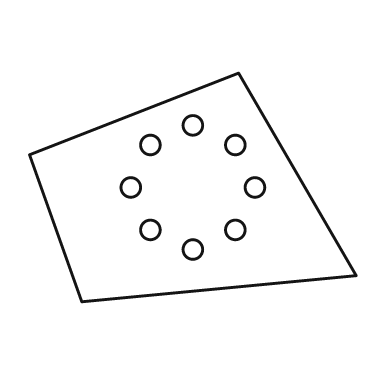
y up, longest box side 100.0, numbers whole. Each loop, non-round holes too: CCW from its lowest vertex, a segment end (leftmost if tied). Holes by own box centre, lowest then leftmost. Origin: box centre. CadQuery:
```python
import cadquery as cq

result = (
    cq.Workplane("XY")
    .moveTo(-34.0, -35.0)
    .lineTo(50.0, -27.0)
    .lineTo(14.0, 35.0)
    .lineTo(-50.0, 10.0)
    .close()
    .moveTo(0.0, -19.0)
    .circle(3.0)
    .moveTo(-13.0, -13.0)
    .circle(3.0)
    .moveTo(13.0, -13.0)
    .circle(3.0)
    .moveTo(-19.0, 0.0)
    .circle(3.0)
    .moveTo(19.0, 0.0)
    .circle(3.0)
    .moveTo(-13.0, 13.0)
    .circle(3.0)
    .moveTo(13.0, 13.0)
    .circle(3.0)
    .moveTo(0.0, 19.0)
    .circle(3.0)
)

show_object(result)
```